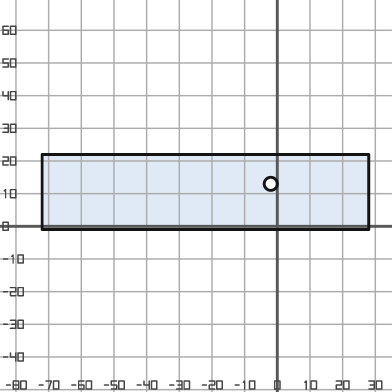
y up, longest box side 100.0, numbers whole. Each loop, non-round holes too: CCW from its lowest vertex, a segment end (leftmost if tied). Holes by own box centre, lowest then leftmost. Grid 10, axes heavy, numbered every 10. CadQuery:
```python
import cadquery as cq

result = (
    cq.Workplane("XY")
    .moveTo(-72.0, -1.0)
    .lineTo(28.0, -1.0)
    .lineTo(28.0, 22.0)
    .lineTo(-72.0, 22.0)
    .close()
    .moveTo(-2.0, 13.0)
    .circle(2.0)
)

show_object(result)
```